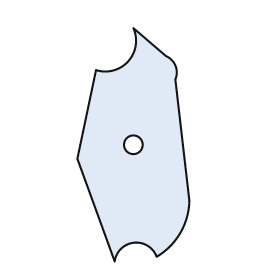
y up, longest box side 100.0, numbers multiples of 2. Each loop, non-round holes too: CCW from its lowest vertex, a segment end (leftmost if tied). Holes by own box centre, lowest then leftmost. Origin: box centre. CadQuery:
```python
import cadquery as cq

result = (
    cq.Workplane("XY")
    .moveTo(-8.0, -50.0)
    .threePointArc((0.0, -42.0), (10.0, -48.0))
    .threePointArc((20.0, -38.0), (24.0, -24.0))
    .lineTo(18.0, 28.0)
    .threePointArc((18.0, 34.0), (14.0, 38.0))
    .lineTo(0.0, 50.0)
    .threePointArc((-2.0, 36.0), (-16.0, 32.0))
    .lineTo(-24.0, -6.0)
    .close()
    .moveTo(0.0, 0.0)
    .circle(4.0)
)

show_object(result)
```